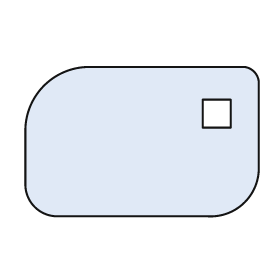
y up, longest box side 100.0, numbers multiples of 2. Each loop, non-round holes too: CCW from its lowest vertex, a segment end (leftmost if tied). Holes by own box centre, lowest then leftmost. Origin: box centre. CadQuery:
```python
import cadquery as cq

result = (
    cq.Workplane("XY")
    .moveTo(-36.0, -32.0)
    .lineTo(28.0, -32.0)
    .threePointArc((44.0, -26.0), (50.0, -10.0))
    .lineTo(50.0, 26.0)
    .threePointArc((48.0, 30.0), (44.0, 32.0))
    .lineTo(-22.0, 32.0)
    .threePointArc((-42.0, 24.0), (-50.0, 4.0))
    .lineTo(-50.0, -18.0)
    .threePointArc((-46.0, -28.0), (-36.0, -32.0))
    .close()
    .moveTo(26.0, 6.0)
    .lineTo(38.0, 6.0)
    .lineTo(38.0, 18.0)
    .lineTo(26.0, 18.0)
    .close()
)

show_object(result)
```